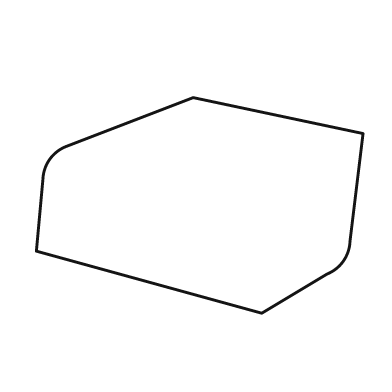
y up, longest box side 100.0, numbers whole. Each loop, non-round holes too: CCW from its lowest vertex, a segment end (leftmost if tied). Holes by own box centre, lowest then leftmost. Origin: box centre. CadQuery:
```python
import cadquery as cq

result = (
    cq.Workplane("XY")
    .moveTo(19.0, -33.0)
    .lineTo(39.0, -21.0)
    .threePointArc((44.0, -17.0), (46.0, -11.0))
    .lineTo(50.0, 22.0)
    .lineTo(-2.0, 33.0)
    .lineTo(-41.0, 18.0)
    .threePointArc((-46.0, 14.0), (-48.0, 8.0))
    .lineTo(-50.0, -14.0)
    .close()
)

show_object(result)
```